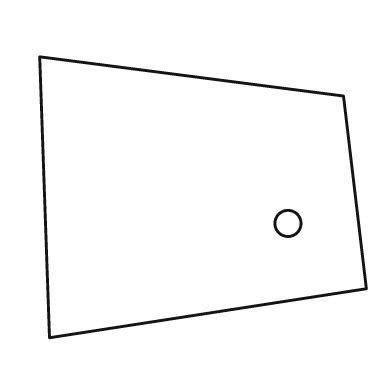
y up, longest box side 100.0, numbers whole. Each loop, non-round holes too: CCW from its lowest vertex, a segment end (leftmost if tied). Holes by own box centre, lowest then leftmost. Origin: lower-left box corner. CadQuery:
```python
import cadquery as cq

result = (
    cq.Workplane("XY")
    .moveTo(3.0, 0.0)
    .lineTo(100.0, 15.0)
    .lineTo(93.0, 74.0)
    .lineTo(0.0, 86.0)
    .close()
    .moveTo(76.0, 35.0)
    .circle(4.0)
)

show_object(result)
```